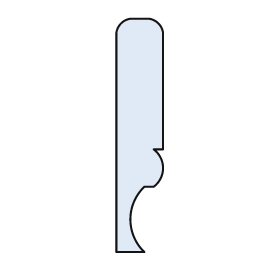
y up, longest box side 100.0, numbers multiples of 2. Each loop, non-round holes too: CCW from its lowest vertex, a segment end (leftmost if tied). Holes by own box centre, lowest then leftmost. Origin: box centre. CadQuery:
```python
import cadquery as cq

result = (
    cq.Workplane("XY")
    .moveTo(-10.0, -50.0)
    .lineTo(2.0, -50.0)
    .threePointArc((-4.0, -36.0), (2.0, -22.0))
    .lineTo(6.0, -22.0)
    .threePointArc((10.0, -14.0), (6.0, -6.0))
    .lineTo(10.0, -6.0)
    .lineTo(10.0, 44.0)
    .threePointArc((8.0, 48.0), (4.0, 50.0))
    .lineTo(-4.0, 50.0)
    .threePointArc((-8.0, 48.0), (-10.0, 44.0))
    .close()
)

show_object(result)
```